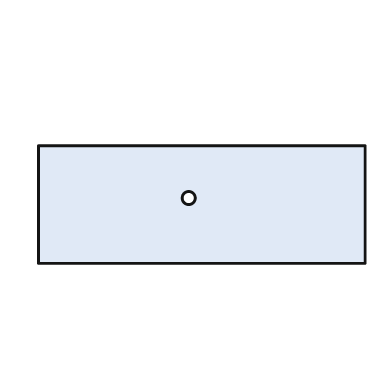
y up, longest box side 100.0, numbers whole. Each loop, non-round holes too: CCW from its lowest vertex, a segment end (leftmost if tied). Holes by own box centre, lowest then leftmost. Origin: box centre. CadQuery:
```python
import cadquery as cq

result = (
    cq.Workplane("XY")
    .moveTo(-50.0, -18.0)
    .lineTo(50.0, -18.0)
    .lineTo(50.0, 18.0)
    .lineTo(-50.0, 18.0)
    .close()
    .moveTo(-4.0, 2.0)
    .circle(2.0)
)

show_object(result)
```